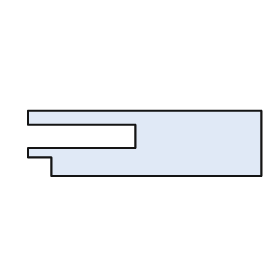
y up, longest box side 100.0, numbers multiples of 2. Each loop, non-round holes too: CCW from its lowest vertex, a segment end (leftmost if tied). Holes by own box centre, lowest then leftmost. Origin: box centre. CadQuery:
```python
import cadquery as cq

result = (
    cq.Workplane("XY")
    .moveTo(-40.0, -14.0)
    .lineTo(50.0, -14.0)
    .lineTo(50.0, 14.0)
    .lineTo(-50.0, 14.0)
    .lineTo(-50.0, 8.0)
    .lineTo(-4.0, 8.0)
    .lineTo(-4.0, -2.0)
    .lineTo(-50.0, -2.0)
    .lineTo(-50.0, -6.0)
    .lineTo(-40.0, -6.0)
    .close()
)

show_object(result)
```